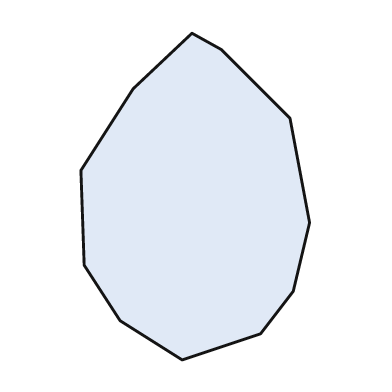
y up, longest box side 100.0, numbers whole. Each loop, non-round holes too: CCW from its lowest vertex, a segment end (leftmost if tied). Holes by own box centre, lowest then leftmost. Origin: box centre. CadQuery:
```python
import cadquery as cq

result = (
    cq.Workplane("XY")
    .moveTo(-4.0, -50.0)
    .lineTo(20.0, -42.0)
    .lineTo(30.0, -29.0)
    .lineTo(35.0, -8.0)
    .lineTo(29.0, 24.0)
    .lineTo(8.0, 45.0)
    .lineTo(-1.0, 50.0)
    .lineTo(-19.0, 33.0)
    .lineTo(-35.0, 8.0)
    .lineTo(-34.0, -21.0)
    .lineTo(-23.0, -38.0)
    .close()
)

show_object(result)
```